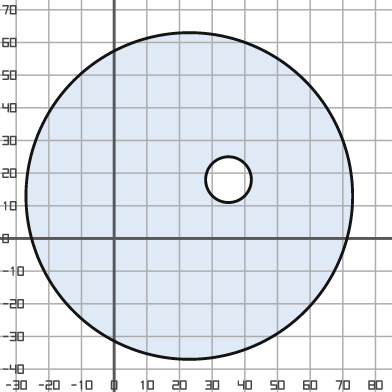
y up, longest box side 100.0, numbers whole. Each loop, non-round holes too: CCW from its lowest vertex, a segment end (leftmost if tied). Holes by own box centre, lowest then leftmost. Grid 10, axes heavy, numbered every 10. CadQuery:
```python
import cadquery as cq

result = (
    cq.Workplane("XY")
    .moveTo(23.0, 13.0)
    .circle(50.0)
    .moveTo(35.0, 18.0)
    .circle(7.0)
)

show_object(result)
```